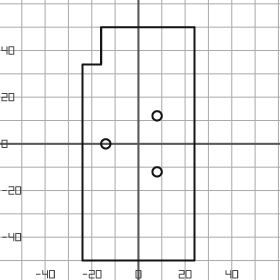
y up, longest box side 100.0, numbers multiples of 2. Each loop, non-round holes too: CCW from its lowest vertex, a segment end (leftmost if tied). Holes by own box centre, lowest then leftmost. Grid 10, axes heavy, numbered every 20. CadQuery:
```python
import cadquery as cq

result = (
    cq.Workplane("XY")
    .moveTo(-24.0, -50.0)
    .lineTo(24.0, -50.0)
    .lineTo(24.0, 50.0)
    .lineTo(-16.0, 50.0)
    .lineTo(-16.0, 34.0)
    .lineTo(-24.0, 34.0)
    .close()
    .moveTo(8.0, -12.0)
    .circle(2.0)
    .moveTo(-14.0, 0.0)
    .circle(2.0)
    .moveTo(8.0, 12.0)
    .circle(2.0)
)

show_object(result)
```